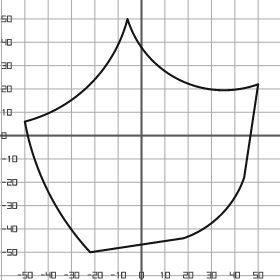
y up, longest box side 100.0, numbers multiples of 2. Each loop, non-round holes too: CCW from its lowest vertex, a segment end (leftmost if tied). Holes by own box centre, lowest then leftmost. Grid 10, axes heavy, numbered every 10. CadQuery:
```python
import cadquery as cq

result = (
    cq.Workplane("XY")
    .moveTo(-22.0, -50.0)
    .lineTo(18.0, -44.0)
    .threePointArc((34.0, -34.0), (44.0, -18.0))
    .lineTo(50.0, 22.0)
    .threePointArc((16.0, 24.0), (-6.0, 50.0))
    .threePointArc((-22.0, 22.0), (-50.0, 6.0))
    .threePointArc((-40.0, -24.0), (-22.0, -50.0))
    .close()
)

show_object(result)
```